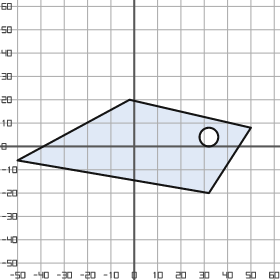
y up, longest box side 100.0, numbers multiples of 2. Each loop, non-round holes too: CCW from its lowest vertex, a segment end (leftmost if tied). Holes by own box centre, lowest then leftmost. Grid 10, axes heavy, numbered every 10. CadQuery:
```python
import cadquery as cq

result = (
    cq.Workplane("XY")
    .moveTo(32.0, -20.0)
    .lineTo(50.0, 8.0)
    .lineTo(-2.0, 20.0)
    .lineTo(-50.0, -6.0)
    .close()
    .moveTo(32.0, 4.0)
    .circle(4.0)
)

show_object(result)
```